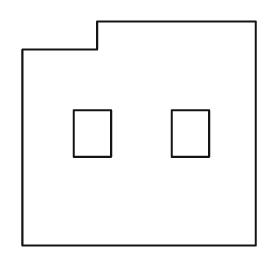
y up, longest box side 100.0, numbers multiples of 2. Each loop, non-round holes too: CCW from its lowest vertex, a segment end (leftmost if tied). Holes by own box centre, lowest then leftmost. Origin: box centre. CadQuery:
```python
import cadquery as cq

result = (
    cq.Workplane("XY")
    .moveTo(-50.0, -48.0)
    .lineTo(50.0, -48.0)
    .lineTo(50.0, 48.0)
    .lineTo(-18.0, 48.0)
    .lineTo(-18.0, 36.0)
    .lineTo(-50.0, 36.0)
    .close()
    .moveTo(-28.0, -10.0)
    .lineTo(-12.0, -10.0)
    .lineTo(-12.0, 10.0)
    .lineTo(-28.0, 10.0)
    .close()
    .moveTo(14.0, -10.0)
    .lineTo(30.0, -10.0)
    .lineTo(30.0, 10.0)
    .lineTo(14.0, 10.0)
    .close()
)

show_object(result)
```